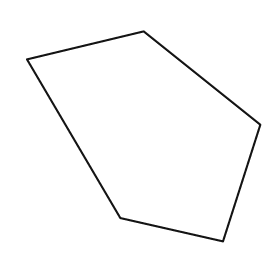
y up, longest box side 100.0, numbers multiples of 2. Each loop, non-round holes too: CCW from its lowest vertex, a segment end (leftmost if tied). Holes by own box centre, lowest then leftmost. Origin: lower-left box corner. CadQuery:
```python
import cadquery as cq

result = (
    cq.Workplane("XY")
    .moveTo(84.0, 0.0)
    .lineTo(100.0, 50.0)
    .lineTo(50.0, 90.0)
    .lineTo(0.0, 78.0)
    .lineTo(40.0, 10.0)
    .close()
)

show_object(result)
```